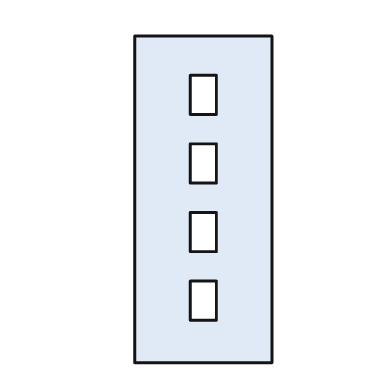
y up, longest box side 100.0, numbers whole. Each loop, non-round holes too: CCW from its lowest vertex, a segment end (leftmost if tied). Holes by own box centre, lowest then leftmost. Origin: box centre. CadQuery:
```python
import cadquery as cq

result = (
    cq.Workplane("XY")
    .moveTo(-21.0, -50.0)
    .lineTo(21.0, -50.0)
    .lineTo(21.0, 50.0)
    .lineTo(-21.0, 50.0)
    .close()
    .moveTo(-4.0, -37.0)
    .lineTo(4.0, -37.0)
    .lineTo(4.0, -25.0)
    .lineTo(-4.0, -25.0)
    .close()
    .moveTo(-4.0, -16.0)
    .lineTo(4.0, -16.0)
    .lineTo(4.0, -4.0)
    .lineTo(-4.0, -4.0)
    .close()
    .moveTo(-4.0, 5.0)
    .lineTo(4.0, 5.0)
    .lineTo(4.0, 17.0)
    .lineTo(-4.0, 17.0)
    .close()
    .moveTo(-4.0, 26.0)
    .lineTo(4.0, 26.0)
    .lineTo(4.0, 38.0)
    .lineTo(-4.0, 38.0)
    .close()
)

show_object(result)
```